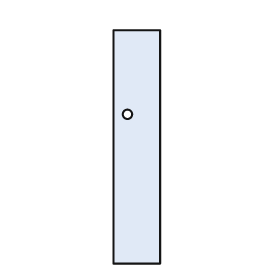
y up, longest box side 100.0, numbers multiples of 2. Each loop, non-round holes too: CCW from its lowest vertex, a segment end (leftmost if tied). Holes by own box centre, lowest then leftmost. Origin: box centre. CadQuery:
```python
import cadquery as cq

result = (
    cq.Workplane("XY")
    .moveTo(-10.0, -50.0)
    .lineTo(10.0, -50.0)
    .lineTo(10.0, 50.0)
    .lineTo(-10.0, 50.0)
    .close()
    .moveTo(-4.0, 14.0)
    .circle(2.0)
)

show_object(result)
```